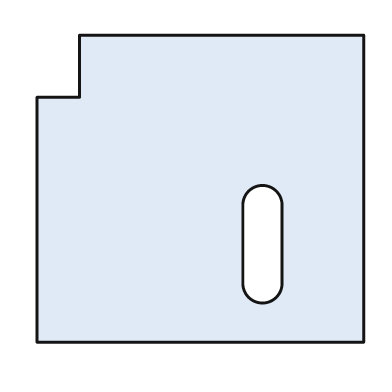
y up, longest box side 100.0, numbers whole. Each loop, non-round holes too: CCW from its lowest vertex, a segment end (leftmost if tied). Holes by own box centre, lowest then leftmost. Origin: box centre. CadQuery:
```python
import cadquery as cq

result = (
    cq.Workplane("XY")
    .moveTo(-50.0, -47.0)
    .lineTo(50.0, -47.0)
    .lineTo(50.0, 47.0)
    .lineTo(-37.0, 47.0)
    .lineTo(-37.0, 28.0)
    .lineTo(-50.0, 28.0)
    .close()
    .moveTo(13.0, -29.0)
    .threePointArc((19.0, -35.0), (25.0, -29.0))
    .lineTo(25.0, -5.0)
    .threePointArc((19.0, 1.0), (13.0, -5.0))
    .close()
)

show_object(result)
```